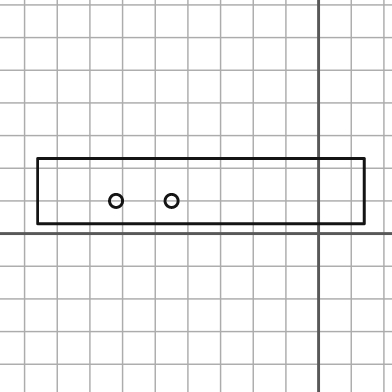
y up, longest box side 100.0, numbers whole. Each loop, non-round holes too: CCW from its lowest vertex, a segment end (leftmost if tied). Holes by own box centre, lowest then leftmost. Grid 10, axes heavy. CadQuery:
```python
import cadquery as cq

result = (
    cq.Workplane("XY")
    .moveTo(-86.0, 3.0)
    .lineTo(14.0, 3.0)
    .lineTo(14.0, 23.0)
    .lineTo(-86.0, 23.0)
    .close()
    .moveTo(-62.0, 10.0)
    .circle(2.0)
    .moveTo(-45.0, 10.0)
    .circle(2.0)
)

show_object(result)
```